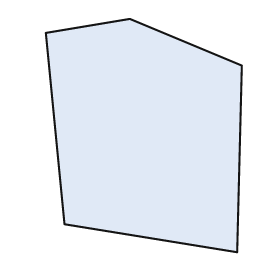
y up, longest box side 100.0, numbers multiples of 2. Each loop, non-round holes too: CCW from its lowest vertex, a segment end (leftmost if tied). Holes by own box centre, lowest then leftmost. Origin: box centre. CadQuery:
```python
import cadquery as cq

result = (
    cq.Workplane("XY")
    .moveTo(40.0, -50.0)
    .lineTo(42.0, 30.0)
    .lineTo(-6.0, 50.0)
    .lineTo(-42.0, 44.0)
    .lineTo(-34.0, -38.0)
    .close()
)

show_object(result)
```